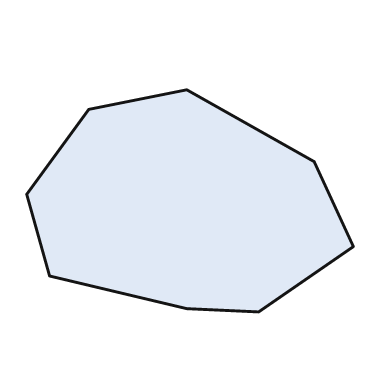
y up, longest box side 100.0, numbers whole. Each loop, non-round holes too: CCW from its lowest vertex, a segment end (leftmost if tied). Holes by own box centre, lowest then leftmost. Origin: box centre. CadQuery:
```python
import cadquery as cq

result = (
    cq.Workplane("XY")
    .moveTo(21.0, -34.0)
    .lineTo(50.0, -14.0)
    .lineTo(38.0, 12.0)
    .lineTo(-1.0, 34.0)
    .lineTo(-31.0, 28.0)
    .lineTo(-50.0, 2.0)
    .lineTo(-43.0, -23.0)
    .lineTo(-1.0, -33.0)
    .close()
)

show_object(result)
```